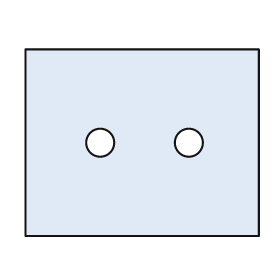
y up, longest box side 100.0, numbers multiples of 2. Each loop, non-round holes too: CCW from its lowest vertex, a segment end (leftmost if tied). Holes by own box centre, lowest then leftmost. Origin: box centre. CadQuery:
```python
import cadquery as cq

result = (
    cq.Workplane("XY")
    .moveTo(-50.0, -40.0)
    .lineTo(50.0, -40.0)
    .lineTo(50.0, 40.0)
    .lineTo(-50.0, 40.0)
    .close()
    .moveTo(-18.0, 0.0)
    .circle(6.0)
    .moveTo(20.0, 0.0)
    .circle(6.0)
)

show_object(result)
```